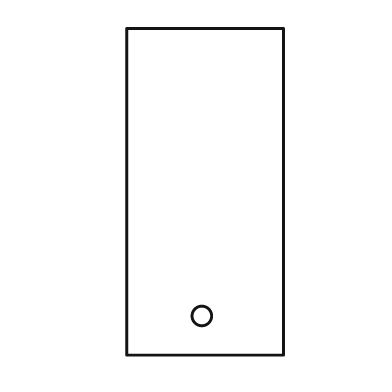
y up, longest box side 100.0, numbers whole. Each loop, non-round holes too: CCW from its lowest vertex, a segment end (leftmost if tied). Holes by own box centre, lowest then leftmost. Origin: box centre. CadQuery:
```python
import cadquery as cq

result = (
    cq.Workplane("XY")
    .moveTo(-24.0, -50.0)
    .lineTo(24.0, -50.0)
    .lineTo(24.0, 50.0)
    .lineTo(-24.0, 50.0)
    .close()
    .moveTo(-1.0, -38.0)
    .circle(3.0)
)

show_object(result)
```